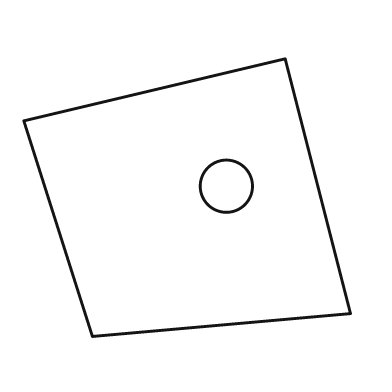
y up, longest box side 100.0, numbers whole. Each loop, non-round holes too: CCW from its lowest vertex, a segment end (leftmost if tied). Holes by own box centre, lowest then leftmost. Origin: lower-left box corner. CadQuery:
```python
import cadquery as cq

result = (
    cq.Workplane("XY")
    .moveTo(21.0, 0.0)
    .lineTo(100.0, 7.0)
    .lineTo(80.0, 85.0)
    .lineTo(0.0, 66.0)
    .close()
    .moveTo(62.0, 46.0)
    .circle(8.0)
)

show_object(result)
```